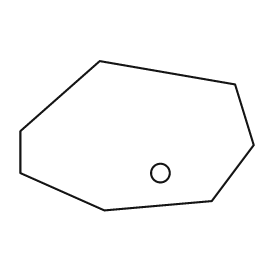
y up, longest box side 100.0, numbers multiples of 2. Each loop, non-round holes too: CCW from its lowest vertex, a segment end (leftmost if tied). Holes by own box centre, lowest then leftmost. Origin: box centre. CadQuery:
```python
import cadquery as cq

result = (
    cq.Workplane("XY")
    .moveTo(-14.0, -32.0)
    .lineTo(32.0, -28.0)
    .lineTo(50.0, -4.0)
    .lineTo(42.0, 22.0)
    .lineTo(-16.0, 32.0)
    .lineTo(-50.0, 2.0)
    .lineTo(-50.0, -16.0)
    .close()
    .moveTo(10.0, -16.0)
    .circle(4.0)
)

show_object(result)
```